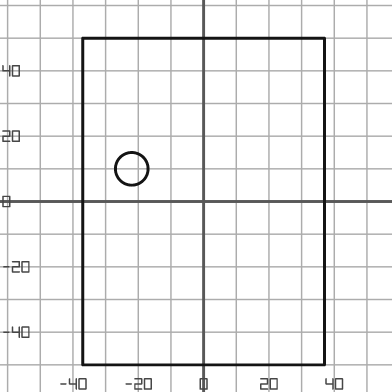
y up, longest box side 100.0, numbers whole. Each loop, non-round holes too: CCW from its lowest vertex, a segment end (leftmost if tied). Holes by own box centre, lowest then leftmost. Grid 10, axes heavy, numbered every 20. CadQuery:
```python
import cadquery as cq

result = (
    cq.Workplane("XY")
    .moveTo(-37.0, -50.0)
    .lineTo(37.0, -50.0)
    .lineTo(37.0, 50.0)
    .lineTo(-37.0, 50.0)
    .close()
    .moveTo(-22.0, 10.0)
    .circle(5.0)
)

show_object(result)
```